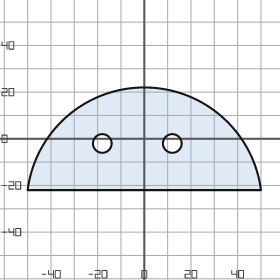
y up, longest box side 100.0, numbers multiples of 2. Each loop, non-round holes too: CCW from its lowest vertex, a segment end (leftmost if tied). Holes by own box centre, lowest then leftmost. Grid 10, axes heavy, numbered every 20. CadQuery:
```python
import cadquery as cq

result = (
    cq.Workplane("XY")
    .moveTo(-50.0, -22.0)
    .lineTo(50.0, -22.0)
    .threePointArc((0.0, 22.0), (-50.0, -22.0))
    .close()
    .moveTo(-18.0, -2.0)
    .circle(4.0)
    .moveTo(12.0, -2.0)
    .circle(4.0)
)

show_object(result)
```